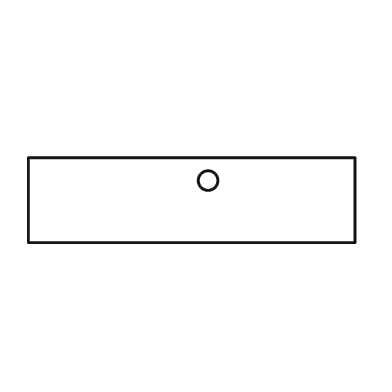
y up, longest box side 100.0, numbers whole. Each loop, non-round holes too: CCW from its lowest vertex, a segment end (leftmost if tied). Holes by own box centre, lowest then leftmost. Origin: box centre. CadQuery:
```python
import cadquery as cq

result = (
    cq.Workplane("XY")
    .moveTo(-50.0, -13.0)
    .lineTo(50.0, -13.0)
    .lineTo(50.0, 13.0)
    .lineTo(-50.0, 13.0)
    .close()
    .moveTo(5.0, 6.0)
    .circle(3.0)
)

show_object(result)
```